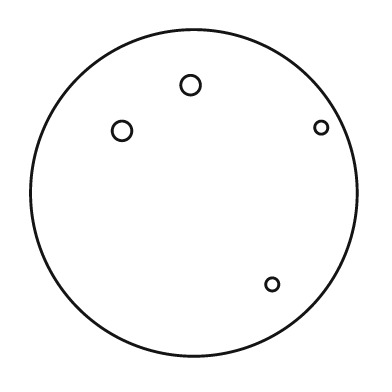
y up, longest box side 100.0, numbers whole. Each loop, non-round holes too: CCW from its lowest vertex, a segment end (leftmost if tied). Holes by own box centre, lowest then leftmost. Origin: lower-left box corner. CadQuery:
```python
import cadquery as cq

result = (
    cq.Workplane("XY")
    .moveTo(50.0, 50.0)
    .circle(50.0)
    .moveTo(74.0, 22.0)
    .circle(2.0)
    .moveTo(28.0, 69.0)
    .circle(3.0)
    .moveTo(89.0, 70.0)
    .circle(2.0)
    .moveTo(49.0, 83.0)
    .circle(3.0)
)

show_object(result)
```